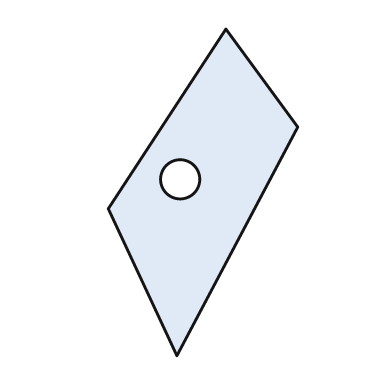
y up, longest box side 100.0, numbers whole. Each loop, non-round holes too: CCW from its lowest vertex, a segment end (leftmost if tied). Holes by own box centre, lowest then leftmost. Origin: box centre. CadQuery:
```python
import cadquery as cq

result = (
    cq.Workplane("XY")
    .moveTo(-8.0, -50.0)
    .lineTo(29.0, 20.0)
    .lineTo(7.0, 50.0)
    .lineTo(-29.0, -5.0)
    .close()
    .moveTo(-7.0, 4.0)
    .circle(6.0)
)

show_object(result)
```